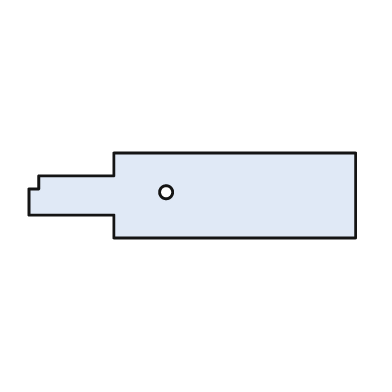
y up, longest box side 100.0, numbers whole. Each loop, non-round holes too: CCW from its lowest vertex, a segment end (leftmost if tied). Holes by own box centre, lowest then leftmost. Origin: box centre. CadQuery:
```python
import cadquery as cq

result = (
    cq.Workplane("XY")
    .moveTo(-24.0, -13.0)
    .lineTo(50.0, -13.0)
    .lineTo(50.0, 13.0)
    .lineTo(-24.0, 13.0)
    .lineTo(-24.0, 6.0)
    .lineTo(-47.0, 6.0)
    .lineTo(-47.0, 2.0)
    .lineTo(-50.0, 2.0)
    .lineTo(-50.0, -6.0)
    .lineTo(-24.0, -6.0)
    .close()
    .moveTo(-8.0, 1.0)
    .circle(2.0)
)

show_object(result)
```